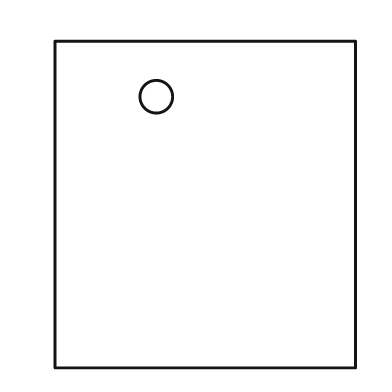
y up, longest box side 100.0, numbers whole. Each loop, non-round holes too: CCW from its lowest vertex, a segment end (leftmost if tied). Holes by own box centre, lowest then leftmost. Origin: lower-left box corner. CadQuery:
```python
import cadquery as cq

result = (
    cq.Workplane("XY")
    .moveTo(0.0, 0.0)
    .lineTo(92.0, 0.0)
    .lineTo(92.0, 100.0)
    .lineTo(0.0, 100.0)
    .close()
    .moveTo(31.0, 83.0)
    .circle(5.0)
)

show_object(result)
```